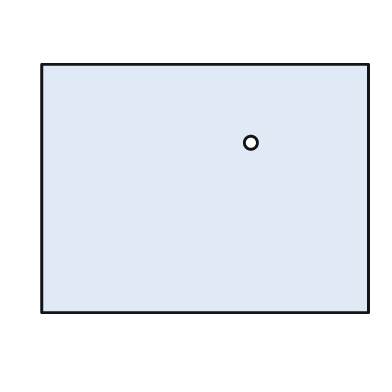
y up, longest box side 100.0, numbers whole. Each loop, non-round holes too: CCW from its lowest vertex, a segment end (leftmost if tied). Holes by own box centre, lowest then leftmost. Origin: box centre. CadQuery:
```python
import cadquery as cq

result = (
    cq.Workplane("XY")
    .moveTo(-50.0, -38.0)
    .lineTo(50.0, -38.0)
    .lineTo(50.0, 38.0)
    .lineTo(-50.0, 38.0)
    .close()
    .moveTo(14.0, 14.0)
    .circle(2.0)
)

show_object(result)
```